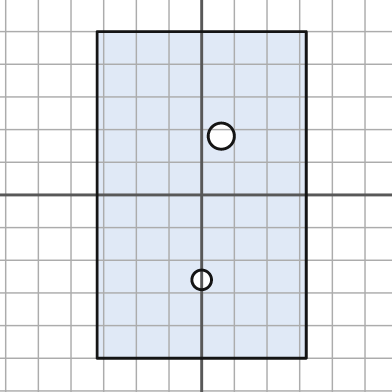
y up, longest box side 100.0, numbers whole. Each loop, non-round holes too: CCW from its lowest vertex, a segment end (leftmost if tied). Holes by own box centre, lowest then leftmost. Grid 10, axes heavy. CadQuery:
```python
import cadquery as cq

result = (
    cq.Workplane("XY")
    .moveTo(-32.0, -50.0)
    .lineTo(32.0, -50.0)
    .lineTo(32.0, 50.0)
    .lineTo(-32.0, 50.0)
    .close()
    .moveTo(0.0, -26.0)
    .circle(3.0)
    .moveTo(6.0, 18.0)
    .circle(4.0)
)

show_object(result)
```